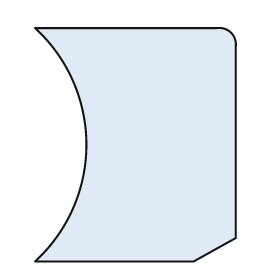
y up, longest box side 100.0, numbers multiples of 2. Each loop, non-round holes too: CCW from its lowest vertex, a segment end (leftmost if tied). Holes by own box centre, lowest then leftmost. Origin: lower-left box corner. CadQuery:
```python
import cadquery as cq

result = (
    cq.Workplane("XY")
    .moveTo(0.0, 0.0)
    .lineTo(68.0, 0.0)
    .lineTo(86.0, 10.0)
    .lineTo(86.0, 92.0)
    .threePointArc((84.0, 98.0), (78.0, 100.0))
    .lineTo(0.0, 100.0)
    .threePointArc((22.0, 50.0), (0.0, 0.0))
    .close()
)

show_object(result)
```